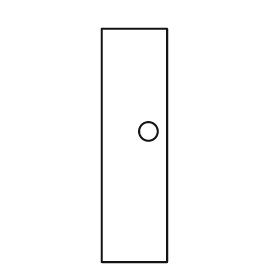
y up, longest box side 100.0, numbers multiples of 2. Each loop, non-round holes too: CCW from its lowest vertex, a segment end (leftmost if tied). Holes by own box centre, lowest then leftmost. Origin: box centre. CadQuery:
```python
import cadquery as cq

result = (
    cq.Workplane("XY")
    .moveTo(-14.0, -50.0)
    .lineTo(14.0, -50.0)
    .lineTo(14.0, 50.0)
    .lineTo(-14.0, 50.0)
    .close()
    .moveTo(6.0, 6.0)
    .circle(4.0)
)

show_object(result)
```